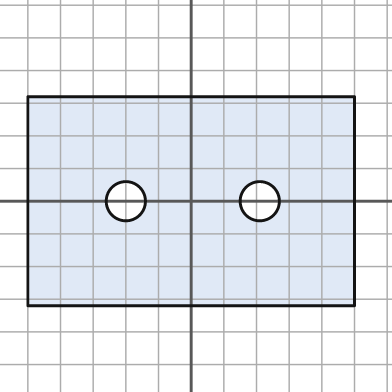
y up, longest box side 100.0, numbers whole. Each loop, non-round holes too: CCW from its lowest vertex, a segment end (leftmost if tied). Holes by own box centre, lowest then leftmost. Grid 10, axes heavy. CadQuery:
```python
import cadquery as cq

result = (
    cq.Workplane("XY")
    .moveTo(-50.0, -32.0)
    .lineTo(50.0, -32.0)
    .lineTo(50.0, 32.0)
    .lineTo(-50.0, 32.0)
    .close()
    .moveTo(-20.0, 0.0)
    .circle(6.0)
    .moveTo(21.0, 0.0)
    .circle(6.0)
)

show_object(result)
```